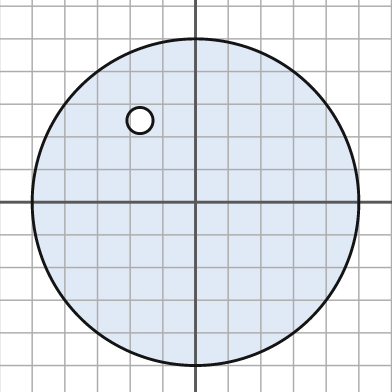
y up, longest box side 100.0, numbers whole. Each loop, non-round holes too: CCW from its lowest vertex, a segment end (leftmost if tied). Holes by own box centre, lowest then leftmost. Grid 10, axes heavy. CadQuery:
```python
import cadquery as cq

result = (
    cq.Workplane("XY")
    .moveTo(0.0, 0.0)
    .circle(50.0)
    .moveTo(-17.0, 25.0)
    .circle(4.0)
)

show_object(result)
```